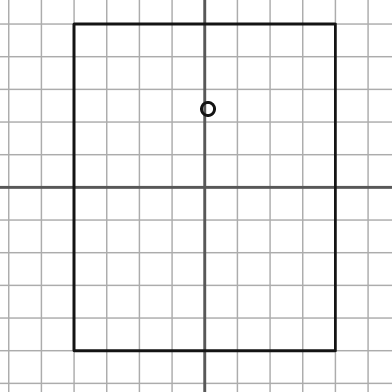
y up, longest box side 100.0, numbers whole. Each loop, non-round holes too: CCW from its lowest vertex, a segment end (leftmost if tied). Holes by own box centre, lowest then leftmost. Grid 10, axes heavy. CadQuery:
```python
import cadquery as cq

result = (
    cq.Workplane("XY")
    .moveTo(-40.0, -50.0)
    .lineTo(40.0, -50.0)
    .lineTo(40.0, 50.0)
    .lineTo(-40.0, 50.0)
    .close()
    .moveTo(1.0, 24.0)
    .circle(2.0)
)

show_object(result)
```